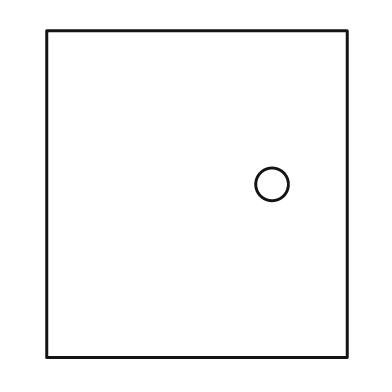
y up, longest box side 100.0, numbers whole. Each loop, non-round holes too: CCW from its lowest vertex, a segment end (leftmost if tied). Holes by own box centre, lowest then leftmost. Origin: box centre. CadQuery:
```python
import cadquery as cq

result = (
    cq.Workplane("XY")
    .moveTo(-46.0, -50.0)
    .lineTo(46.0, -50.0)
    .lineTo(46.0, 50.0)
    .lineTo(-46.0, 50.0)
    .close()
    .moveTo(23.0, 3.0)
    .circle(5.0)
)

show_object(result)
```